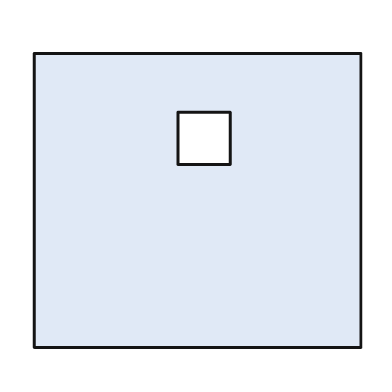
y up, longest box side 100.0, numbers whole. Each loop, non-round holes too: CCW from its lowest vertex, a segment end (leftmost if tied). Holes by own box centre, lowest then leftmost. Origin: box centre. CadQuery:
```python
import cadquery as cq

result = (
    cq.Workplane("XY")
    .moveTo(-50.0, -45.0)
    .lineTo(50.0, -45.0)
    .lineTo(50.0, 45.0)
    .lineTo(-50.0, 45.0)
    .close()
    .moveTo(-6.0, 11.0)
    .lineTo(10.0, 11.0)
    .lineTo(10.0, 27.0)
    .lineTo(-6.0, 27.0)
    .close()
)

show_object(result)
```